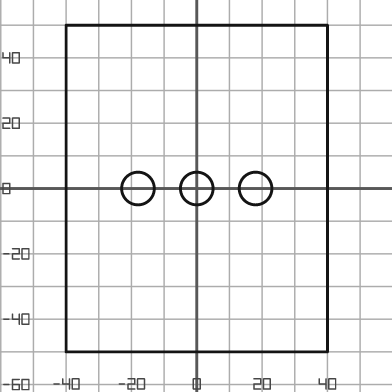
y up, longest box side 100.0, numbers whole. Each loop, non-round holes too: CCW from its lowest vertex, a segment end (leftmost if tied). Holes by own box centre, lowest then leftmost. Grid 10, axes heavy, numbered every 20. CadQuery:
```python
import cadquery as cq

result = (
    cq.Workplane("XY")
    .moveTo(-40.0, -50.0)
    .lineTo(40.0, -50.0)
    .lineTo(40.0, 50.0)
    .lineTo(-40.0, 50.0)
    .close()
    .moveTo(-18.0, 0.0)
    .circle(5.0)
    .moveTo(0.0, 0.0)
    .circle(5.0)
    .moveTo(18.0, 0.0)
    .circle(5.0)
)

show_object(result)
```